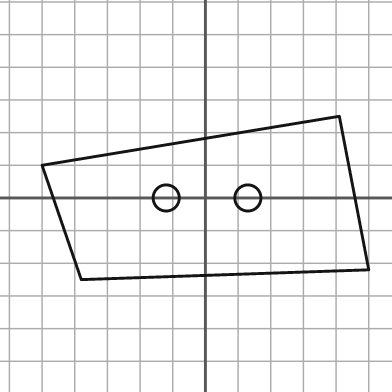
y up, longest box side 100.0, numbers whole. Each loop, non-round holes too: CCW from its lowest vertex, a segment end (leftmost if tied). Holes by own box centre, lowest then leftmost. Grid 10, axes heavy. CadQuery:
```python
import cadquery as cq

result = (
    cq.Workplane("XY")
    .moveTo(-38.0, -25.0)
    .lineTo(50.0, -22.0)
    .lineTo(41.0, 25.0)
    .lineTo(-50.0, 10.0)
    .close()
    .moveTo(-12.0, 0.0)
    .circle(4.0)
    .moveTo(13.0, 0.0)
    .circle(4.0)
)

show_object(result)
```